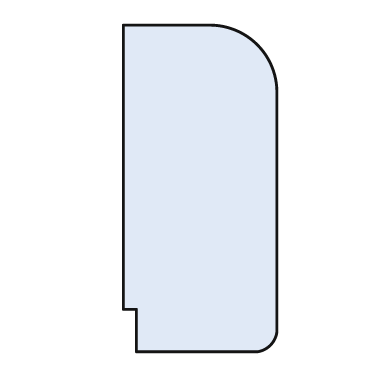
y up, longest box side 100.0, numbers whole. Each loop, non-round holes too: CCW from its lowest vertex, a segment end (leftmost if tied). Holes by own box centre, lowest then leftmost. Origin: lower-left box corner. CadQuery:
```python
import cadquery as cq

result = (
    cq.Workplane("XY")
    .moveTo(4.0, 0.0)
    .lineTo(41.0, 0.0)
    .threePointArc((45.0, 2.0), (47.0, 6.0))
    .lineTo(47.0, 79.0)
    .threePointArc((41.0, 94.0), (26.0, 100.0))
    .lineTo(0.0, 100.0)
    .lineTo(0.0, 13.0)
    .lineTo(4.0, 13.0)
    .close()
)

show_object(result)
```